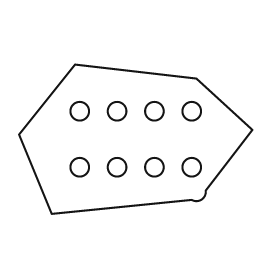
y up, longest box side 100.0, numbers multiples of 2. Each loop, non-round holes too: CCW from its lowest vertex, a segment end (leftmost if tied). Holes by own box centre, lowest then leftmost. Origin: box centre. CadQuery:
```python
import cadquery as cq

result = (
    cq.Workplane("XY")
    .moveTo(-36.0, -32.0)
    .lineTo(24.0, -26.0)
    .threePointArc((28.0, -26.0), (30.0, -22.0))
    .lineTo(50.0, 4.0)
    .lineTo(26.0, 26.0)
    .lineTo(-26.0, 32.0)
    .lineTo(-50.0, 2.0)
    .close()
    .moveTo(-24.0, -12.0)
    .circle(4.0)
    .moveTo(-8.0, -12.0)
    .circle(4.0)
    .moveTo(8.0, -12.0)
    .circle(4.0)
    .moveTo(24.0, -12.0)
    .circle(4.0)
    .moveTo(-24.0, 12.0)
    .circle(4.0)
    .moveTo(-8.0, 12.0)
    .circle(4.0)
    .moveTo(8.0, 12.0)
    .circle(4.0)
    .moveTo(24.0, 12.0)
    .circle(4.0)
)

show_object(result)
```